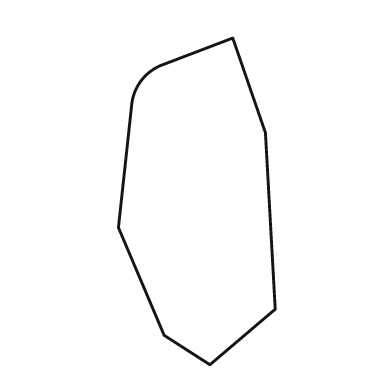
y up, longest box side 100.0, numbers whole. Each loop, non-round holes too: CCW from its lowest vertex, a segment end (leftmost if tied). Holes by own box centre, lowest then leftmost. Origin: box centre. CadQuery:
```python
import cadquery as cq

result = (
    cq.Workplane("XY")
    .moveTo(4.0, -50.0)
    .lineTo(24.0, -33.0)
    .lineTo(21.0, 21.0)
    .lineTo(11.0, 50.0)
    .lineTo(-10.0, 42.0)
    .threePointArc((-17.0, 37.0), (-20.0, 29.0))
    .lineTo(-24.0, -8.0)
    .lineTo(-10.0, -41.0)
    .close()
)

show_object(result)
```